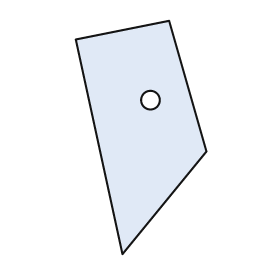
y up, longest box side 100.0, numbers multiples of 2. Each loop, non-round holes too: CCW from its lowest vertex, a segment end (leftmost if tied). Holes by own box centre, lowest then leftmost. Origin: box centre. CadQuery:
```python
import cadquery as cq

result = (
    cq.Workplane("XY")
    .moveTo(-8.0, -50.0)
    .lineTo(28.0, -6.0)
    .lineTo(12.0, 50.0)
    .lineTo(-28.0, 42.0)
    .close()
    .moveTo(4.0, 16.0)
    .circle(4.0)
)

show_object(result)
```